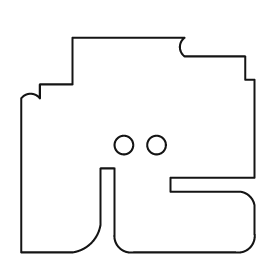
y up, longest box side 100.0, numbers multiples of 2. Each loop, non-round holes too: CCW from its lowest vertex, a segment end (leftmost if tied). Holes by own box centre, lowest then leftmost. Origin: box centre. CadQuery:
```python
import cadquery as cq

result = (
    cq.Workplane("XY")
    .moveTo(-50.0, -46.0)
    .lineTo(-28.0, -46.0)
    .threePointArc((-20.0, -42.0), (-16.0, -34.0))
    .lineTo(-16.0, -10.0)
    .lineTo(-10.0, -10.0)
    .lineTo(-10.0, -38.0)
    .threePointArc((-8.0, -44.0), (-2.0, -46.0))
    .lineTo(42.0, -46.0)
    .threePointArc((48.0, -44.0), (50.0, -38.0))
    .lineTo(50.0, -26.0)
    .threePointArc((48.0, -22.0), (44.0, -20.0))
    .lineTo(14.0, -20.0)
    .lineTo(14.0, -14.0)
    .lineTo(50.0, -14.0)
    .lineTo(50.0, 28.0)
    .lineTo(46.0, 28.0)
    .lineTo(46.0, 38.0)
    .lineTo(20.0, 38.0)
    .threePointArc((18.0, 42.0), (20.0, 46.0))
    .lineTo(-28.0, 46.0)
    .lineTo(-28.0, 26.0)
    .lineTo(-42.0, 26.0)
    .lineTo(-42.0, 20.0)
    .threePointArc((-46.0, 22.0), (-50.0, 20.0))
    .close()
    .moveTo(-6.0, 0.0)
    .circle(4.0)
    .moveTo(8.0, 0.0)
    .circle(4.0)
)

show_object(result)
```